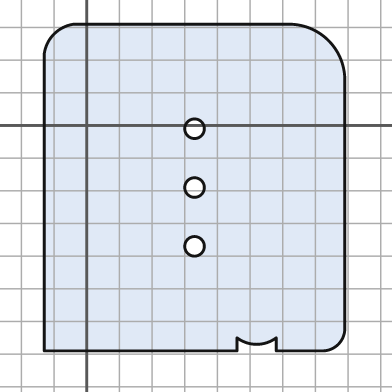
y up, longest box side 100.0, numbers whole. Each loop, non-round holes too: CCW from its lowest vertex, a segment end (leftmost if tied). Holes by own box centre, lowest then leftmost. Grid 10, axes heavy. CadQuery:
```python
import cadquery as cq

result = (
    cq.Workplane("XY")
    .moveTo(-13.0, -69.0)
    .lineTo(46.0, -69.0)
    .lineTo(46.0, -65.0)
    .threePointArc((52.0, -67.0), (58.0, -65.0))
    .lineTo(58.0, -69.0)
    .lineTo(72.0, -69.0)
    .threePointArc((77.0, -67.0), (79.0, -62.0))
    .lineTo(79.0, 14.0)
    .threePointArc((74.0, 26.0), (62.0, 31.0))
    .lineTo(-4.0, 31.0)
    .threePointArc((-10.0, 28.0), (-13.0, 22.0))
    .close()
    .moveTo(33.0, -37.0)
    .circle(3.0)
    .moveTo(33.0, -19.0)
    .circle(3.0)
    .moveTo(33.0, -1.0)
    .circle(3.0)
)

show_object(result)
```